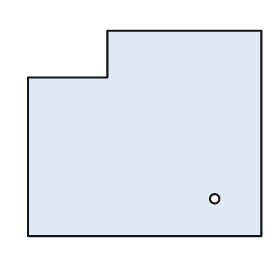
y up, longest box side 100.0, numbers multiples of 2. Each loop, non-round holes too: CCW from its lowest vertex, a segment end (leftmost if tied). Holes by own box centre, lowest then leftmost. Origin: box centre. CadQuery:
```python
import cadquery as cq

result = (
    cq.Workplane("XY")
    .moveTo(-50.0, -44.0)
    .lineTo(50.0, -44.0)
    .lineTo(50.0, 44.0)
    .lineTo(-16.0, 44.0)
    .lineTo(-16.0, 24.0)
    .lineTo(-50.0, 24.0)
    .close()
    .moveTo(30.0, -28.0)
    .circle(2.0)
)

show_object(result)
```